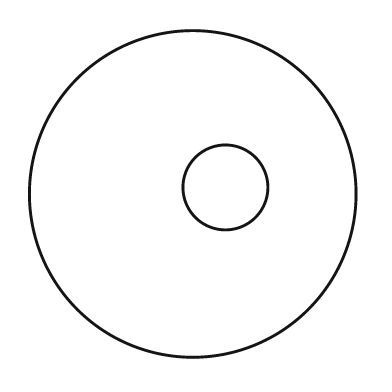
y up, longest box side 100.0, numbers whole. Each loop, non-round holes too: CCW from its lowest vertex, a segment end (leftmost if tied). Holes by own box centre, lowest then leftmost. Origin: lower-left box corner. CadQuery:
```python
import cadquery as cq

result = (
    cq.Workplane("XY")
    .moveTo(50.0, 50.0)
    .circle(50.0)
    .moveTo(60.0, 52.0)
    .circle(13.0)
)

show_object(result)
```